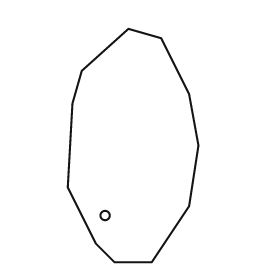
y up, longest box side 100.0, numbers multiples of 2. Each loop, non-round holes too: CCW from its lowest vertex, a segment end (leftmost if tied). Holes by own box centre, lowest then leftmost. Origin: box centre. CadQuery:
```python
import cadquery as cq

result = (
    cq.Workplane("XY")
    .moveTo(-8.0, -50.0)
    .lineTo(8.0, -50.0)
    .lineTo(24.0, -26.0)
    .lineTo(28.0, 0.0)
    .lineTo(24.0, 22.0)
    .lineTo(12.0, 46.0)
    .lineTo(-2.0, 50.0)
    .lineTo(-22.0, 32.0)
    .lineTo(-26.0, 18.0)
    .lineTo(-28.0, -18.0)
    .lineTo(-16.0, -42.0)
    .close()
    .moveTo(-12.0, -30.0)
    .circle(2.0)
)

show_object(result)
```